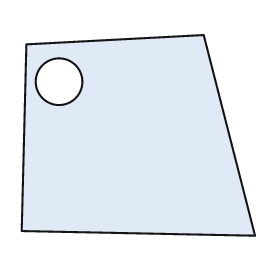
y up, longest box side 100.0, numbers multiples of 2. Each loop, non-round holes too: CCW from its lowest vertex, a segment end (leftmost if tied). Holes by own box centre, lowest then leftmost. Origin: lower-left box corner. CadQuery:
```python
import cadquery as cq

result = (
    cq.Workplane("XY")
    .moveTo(100.0, 0.0)
    .lineTo(78.0, 86.0)
    .lineTo(2.0, 82.0)
    .lineTo(0.0, 2.0)
    .close()
    .moveTo(16.0, 66.0)
    .circle(10.0)
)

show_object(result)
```